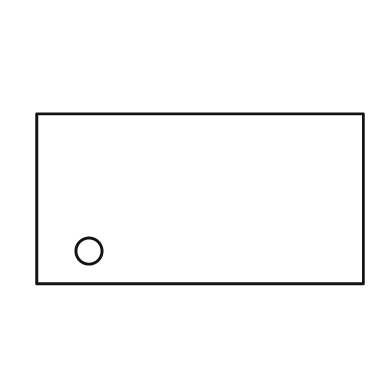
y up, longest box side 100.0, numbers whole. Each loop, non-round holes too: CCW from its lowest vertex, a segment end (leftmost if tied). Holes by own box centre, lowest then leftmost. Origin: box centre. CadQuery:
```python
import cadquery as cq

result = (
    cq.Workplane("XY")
    .moveTo(-50.0, -26.0)
    .lineTo(50.0, -26.0)
    .lineTo(50.0, 26.0)
    .lineTo(-50.0, 26.0)
    .close()
    .moveTo(-34.0, -16.0)
    .circle(4.0)
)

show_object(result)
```